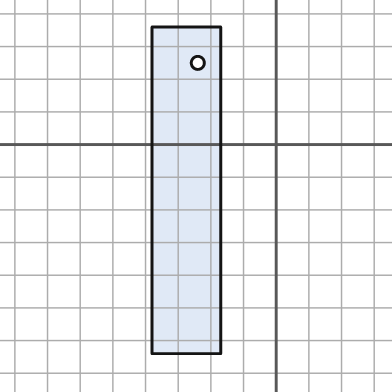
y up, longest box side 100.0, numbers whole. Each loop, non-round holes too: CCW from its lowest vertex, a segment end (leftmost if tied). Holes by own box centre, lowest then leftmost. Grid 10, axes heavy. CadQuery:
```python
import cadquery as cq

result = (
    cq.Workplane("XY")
    .moveTo(-38.0, -64.0)
    .lineTo(-17.0, -64.0)
    .lineTo(-17.0, 36.0)
    .lineTo(-38.0, 36.0)
    .close()
    .moveTo(-24.0, 25.0)
    .circle(2.0)
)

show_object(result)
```